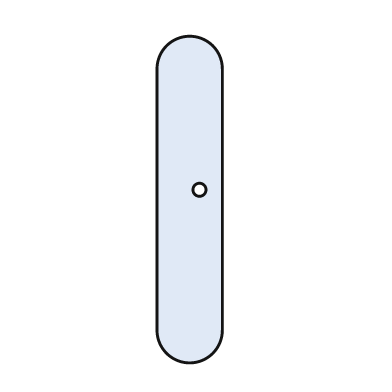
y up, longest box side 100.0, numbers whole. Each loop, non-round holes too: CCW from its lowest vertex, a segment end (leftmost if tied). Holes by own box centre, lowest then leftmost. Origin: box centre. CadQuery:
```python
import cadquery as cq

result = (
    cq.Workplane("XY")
    .moveTo(-10.0, -40.0)
    .threePointArc((0.0, -50.0), (10.0, -40.0))
    .lineTo(10.0, 40.0)
    .threePointArc((0.0, 50.0), (-10.0, 40.0))
    .close()
    .moveTo(3.0, 3.0)
    .circle(2.0)
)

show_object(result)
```